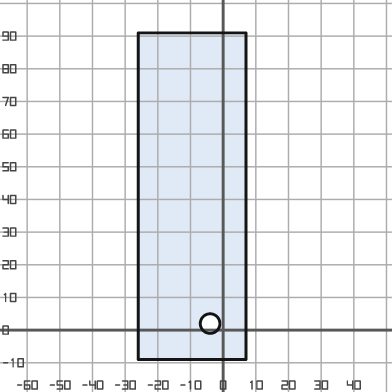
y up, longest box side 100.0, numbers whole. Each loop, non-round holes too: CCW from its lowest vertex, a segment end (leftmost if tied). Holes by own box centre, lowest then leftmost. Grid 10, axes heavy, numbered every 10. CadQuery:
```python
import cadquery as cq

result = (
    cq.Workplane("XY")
    .moveTo(-26.0, -9.0)
    .lineTo(7.0, -9.0)
    .lineTo(7.0, 91.0)
    .lineTo(-26.0, 91.0)
    .close()
    .moveTo(-4.0, 2.0)
    .circle(3.0)
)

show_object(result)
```